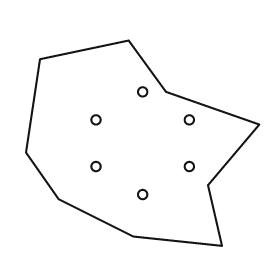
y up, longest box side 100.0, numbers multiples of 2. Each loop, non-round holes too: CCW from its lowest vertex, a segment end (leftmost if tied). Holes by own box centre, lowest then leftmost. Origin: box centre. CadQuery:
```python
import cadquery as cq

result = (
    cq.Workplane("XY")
    .moveTo(34.0, -44.0)
    .lineTo(28.0, -18.0)
    .lineTo(50.0, 8.0)
    .lineTo(10.0, 22.0)
    .lineTo(-6.0, 44.0)
    .lineTo(-44.0, 36.0)
    .lineTo(-50.0, -4.0)
    .lineTo(-36.0, -24.0)
    .lineTo(-4.0, -40.0)
    .close()
    .moveTo(0.0, -22.0)
    .circle(2.0)
    .moveTo(-20.0, -10.0)
    .circle(2.0)
    .moveTo(20.0, -10.0)
    .circle(2.0)
    .moveTo(-20.0, 10.0)
    .circle(2.0)
    .moveTo(20.0, 10.0)
    .circle(2.0)
    .moveTo(0.0, 22.0)
    .circle(2.0)
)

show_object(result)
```